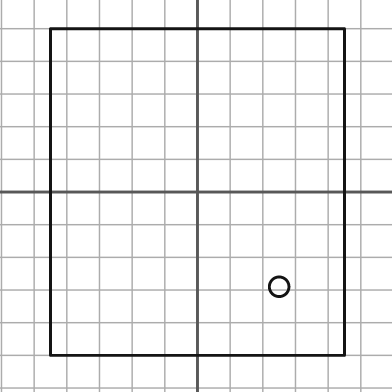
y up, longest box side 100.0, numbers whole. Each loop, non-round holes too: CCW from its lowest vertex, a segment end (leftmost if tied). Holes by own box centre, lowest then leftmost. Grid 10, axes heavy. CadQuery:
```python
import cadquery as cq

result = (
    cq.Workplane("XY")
    .moveTo(-45.0, -50.0)
    .lineTo(45.0, -50.0)
    .lineTo(45.0, 50.0)
    .lineTo(-45.0, 50.0)
    .close()
    .moveTo(25.0, -29.0)
    .circle(3.0)
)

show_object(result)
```